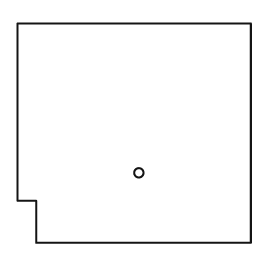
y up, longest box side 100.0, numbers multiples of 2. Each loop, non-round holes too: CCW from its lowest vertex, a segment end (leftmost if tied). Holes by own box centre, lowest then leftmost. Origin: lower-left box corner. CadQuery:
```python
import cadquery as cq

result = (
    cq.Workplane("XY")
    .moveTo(8.0, 0.0)
    .lineTo(100.0, 0.0)
    .lineTo(100.0, 94.0)
    .lineTo(0.0, 94.0)
    .lineTo(0.0, 18.0)
    .lineTo(8.0, 18.0)
    .close()
    .moveTo(52.0, 30.0)
    .circle(2.0)
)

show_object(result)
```